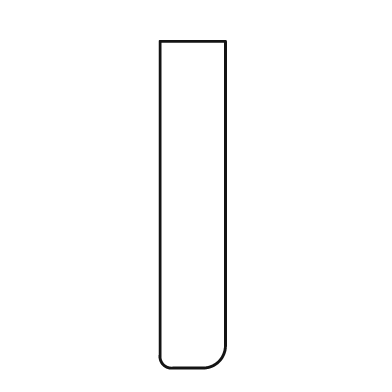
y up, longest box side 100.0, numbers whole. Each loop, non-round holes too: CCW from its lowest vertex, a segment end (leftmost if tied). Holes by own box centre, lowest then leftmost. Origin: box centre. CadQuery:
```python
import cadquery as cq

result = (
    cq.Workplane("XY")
    .moveTo(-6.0, -50.0)
    .lineTo(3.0, -50.0)
    .threePointArc((8.0, -48.0), (10.0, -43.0))
    .lineTo(10.0, 50.0)
    .lineTo(-10.0, 50.0)
    .lineTo(-10.0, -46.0)
    .threePointArc((-9.0, -49.0), (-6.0, -50.0))
    .close()
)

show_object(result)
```